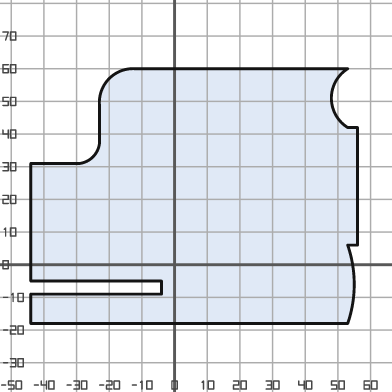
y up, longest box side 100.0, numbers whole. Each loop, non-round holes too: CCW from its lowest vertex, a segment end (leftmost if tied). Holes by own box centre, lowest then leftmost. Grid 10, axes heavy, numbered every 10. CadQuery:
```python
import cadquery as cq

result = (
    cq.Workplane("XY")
    .moveTo(-44.0, -18.0)
    .lineTo(53.0, -18.0)
    .threePointArc((55.0, -6.0), (53.0, 6.0))
    .lineTo(56.0, 6.0)
    .lineTo(56.0, 42.0)
    .lineTo(53.0, 42.0)
    .threePointArc((48.0, 51.0), (53.0, 60.0))
    .lineTo(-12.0, 60.0)
    .threePointArc((-20.0, 57.0), (-23.0, 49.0))
    .lineTo(-23.0, 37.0)
    .threePointArc((-25.0, 33.0), (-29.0, 31.0))
    .lineTo(-44.0, 31.0)
    .lineTo(-44.0, -5.0)
    .lineTo(-4.0, -5.0)
    .lineTo(-4.0, -9.0)
    .lineTo(-44.0, -9.0)
    .close()
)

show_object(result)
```